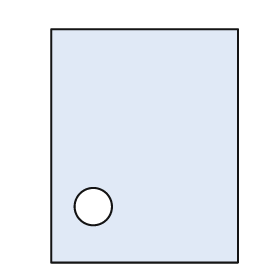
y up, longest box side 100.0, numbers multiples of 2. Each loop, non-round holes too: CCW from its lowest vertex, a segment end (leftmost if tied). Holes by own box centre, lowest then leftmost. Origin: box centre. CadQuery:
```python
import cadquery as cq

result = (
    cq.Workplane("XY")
    .moveTo(-40.0, -50.0)
    .lineTo(40.0, -50.0)
    .lineTo(40.0, 50.0)
    .lineTo(-40.0, 50.0)
    .close()
    .moveTo(-22.0, -26.0)
    .circle(8.0)
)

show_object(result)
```